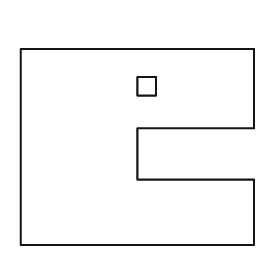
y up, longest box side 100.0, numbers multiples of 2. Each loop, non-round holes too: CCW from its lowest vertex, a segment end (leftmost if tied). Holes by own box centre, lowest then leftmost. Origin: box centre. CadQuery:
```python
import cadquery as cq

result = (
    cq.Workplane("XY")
    .moveTo(-50.0, -42.0)
    .lineTo(50.0, -42.0)
    .lineTo(50.0, -14.0)
    .lineTo(0.0, -14.0)
    .lineTo(0.0, 8.0)
    .lineTo(50.0, 8.0)
    .lineTo(50.0, 42.0)
    .lineTo(-50.0, 42.0)
    .close()
    .moveTo(0.0, 22.0)
    .lineTo(8.0, 22.0)
    .lineTo(8.0, 30.0)
    .lineTo(0.0, 30.0)
    .close()
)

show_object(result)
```